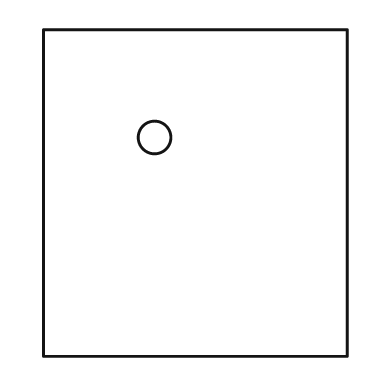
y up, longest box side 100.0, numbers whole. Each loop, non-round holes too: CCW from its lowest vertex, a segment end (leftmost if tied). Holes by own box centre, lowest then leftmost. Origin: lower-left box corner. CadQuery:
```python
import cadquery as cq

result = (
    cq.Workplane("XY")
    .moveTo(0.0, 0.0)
    .lineTo(93.0, 0.0)
    .lineTo(93.0, 100.0)
    .lineTo(0.0, 100.0)
    .close()
    .moveTo(34.0, 67.0)
    .circle(5.0)
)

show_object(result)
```